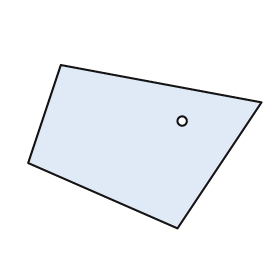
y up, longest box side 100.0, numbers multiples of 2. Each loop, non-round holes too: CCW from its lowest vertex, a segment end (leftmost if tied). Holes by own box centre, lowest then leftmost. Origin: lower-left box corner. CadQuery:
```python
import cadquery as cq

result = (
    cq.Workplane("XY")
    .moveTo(64.0, 0.0)
    .lineTo(100.0, 54.0)
    .lineTo(14.0, 70.0)
    .lineTo(0.0, 28.0)
    .close()
    .moveTo(66.0, 46.0)
    .circle(2.0)
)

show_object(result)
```